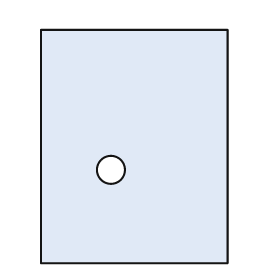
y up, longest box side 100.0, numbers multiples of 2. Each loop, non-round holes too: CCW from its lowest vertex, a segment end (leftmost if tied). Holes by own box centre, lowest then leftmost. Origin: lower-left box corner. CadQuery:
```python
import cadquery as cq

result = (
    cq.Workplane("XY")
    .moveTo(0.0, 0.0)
    .lineTo(80.0, 0.0)
    .lineTo(80.0, 100.0)
    .lineTo(0.0, 100.0)
    .close()
    .moveTo(30.0, 40.0)
    .circle(6.0)
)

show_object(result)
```